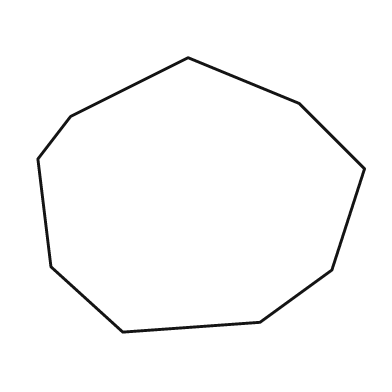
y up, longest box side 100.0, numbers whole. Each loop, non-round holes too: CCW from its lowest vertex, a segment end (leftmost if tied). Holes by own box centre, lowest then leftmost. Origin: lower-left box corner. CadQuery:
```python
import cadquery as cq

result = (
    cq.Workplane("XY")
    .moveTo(26.0, 0.0)
    .lineTo(68.0, 3.0)
    .lineTo(90.0, 19.0)
    .lineTo(100.0, 50.0)
    .lineTo(80.0, 70.0)
    .lineTo(46.0, 84.0)
    .lineTo(10.0, 66.0)
    .lineTo(0.0, 53.0)
    .lineTo(4.0, 20.0)
    .close()
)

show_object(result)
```